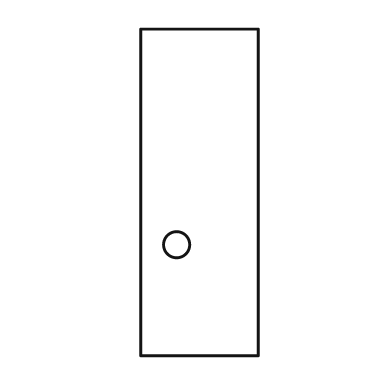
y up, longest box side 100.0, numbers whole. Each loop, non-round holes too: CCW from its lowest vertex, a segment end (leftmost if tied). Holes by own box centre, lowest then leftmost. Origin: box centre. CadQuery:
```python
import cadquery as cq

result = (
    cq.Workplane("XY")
    .moveTo(-18.0, -50.0)
    .lineTo(18.0, -50.0)
    .lineTo(18.0, 50.0)
    .lineTo(-18.0, 50.0)
    .close()
    .moveTo(-7.0, -16.0)
    .circle(4.0)
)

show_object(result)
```